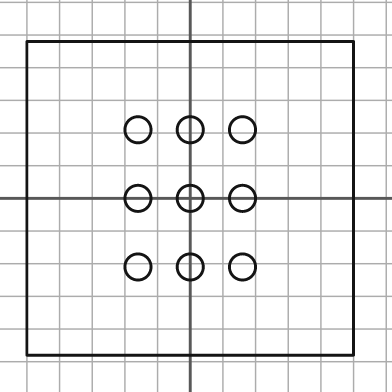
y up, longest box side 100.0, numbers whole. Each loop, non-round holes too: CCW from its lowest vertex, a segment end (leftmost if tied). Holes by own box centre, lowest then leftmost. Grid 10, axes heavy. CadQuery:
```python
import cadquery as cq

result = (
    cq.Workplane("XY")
    .moveTo(-50.0, -48.0)
    .lineTo(50.0, -48.0)
    .lineTo(50.0, 48.0)
    .lineTo(-50.0, 48.0)
    .close()
    .moveTo(-16.0, -21.0)
    .circle(4.0)
    .moveTo(0.0, -21.0)
    .circle(4.0)
    .moveTo(16.0, -21.0)
    .circle(4.0)
    .moveTo(-16.0, 0.0)
    .circle(4.0)
    .moveTo(0.0, 0.0)
    .circle(4.0)
    .moveTo(16.0, 0.0)
    .circle(4.0)
    .moveTo(-16.0, 21.0)
    .circle(4.0)
    .moveTo(0.0, 21.0)
    .circle(4.0)
    .moveTo(16.0, 21.0)
    .circle(4.0)
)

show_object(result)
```